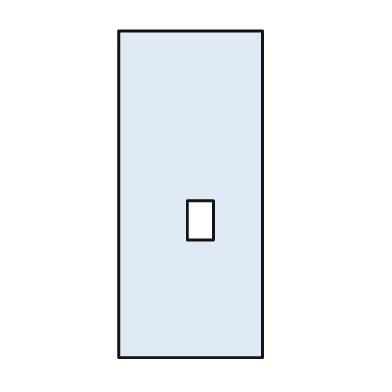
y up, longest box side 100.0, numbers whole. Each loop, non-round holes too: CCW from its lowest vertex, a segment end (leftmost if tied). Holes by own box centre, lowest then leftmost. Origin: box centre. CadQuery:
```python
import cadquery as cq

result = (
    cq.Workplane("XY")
    .moveTo(-22.0, -50.0)
    .lineTo(22.0, -50.0)
    .lineTo(22.0, 50.0)
    .lineTo(-22.0, 50.0)
    .close()
    .moveTo(-1.0, -14.0)
    .lineTo(7.0, -14.0)
    .lineTo(7.0, -2.0)
    .lineTo(-1.0, -2.0)
    .close()
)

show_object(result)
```